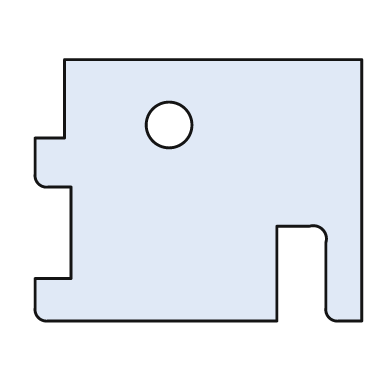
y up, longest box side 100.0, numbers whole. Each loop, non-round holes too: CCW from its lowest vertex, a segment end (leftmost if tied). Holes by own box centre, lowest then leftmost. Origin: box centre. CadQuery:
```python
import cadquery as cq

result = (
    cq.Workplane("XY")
    .moveTo(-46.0, -40.0)
    .lineTo(24.0, -40.0)
    .lineTo(24.0, -11.0)
    .lineTo(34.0, -11.0)
    .threePointArc((38.0, -12.0), (39.0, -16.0))
    .lineTo(39.0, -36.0)
    .threePointArc((40.0, -39.0), (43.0, -40.0))
    .lineTo(50.0, -40.0)
    .lineTo(50.0, 40.0)
    .lineTo(-41.0, 40.0)
    .lineTo(-41.0, 16.0)
    .lineTo(-50.0, 16.0)
    .lineTo(-50.0, 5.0)
    .threePointArc((-49.0, 2.0), (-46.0, 1.0))
    .lineTo(-39.0, 1.0)
    .lineTo(-39.0, -27.0)
    .lineTo(-50.0, -27.0)
    .lineTo(-50.0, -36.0)
    .threePointArc((-49.0, -39.0), (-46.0, -40.0))
    .close()
    .moveTo(-9.0, 20.0)
    .circle(7.0)
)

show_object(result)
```